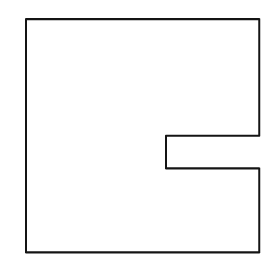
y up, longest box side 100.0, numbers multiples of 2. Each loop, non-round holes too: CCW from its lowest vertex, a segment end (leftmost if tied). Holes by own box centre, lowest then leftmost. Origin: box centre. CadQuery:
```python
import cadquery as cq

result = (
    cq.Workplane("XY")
    .moveTo(-50.0, -50.0)
    .lineTo(50.0, -50.0)
    .lineTo(50.0, -14.0)
    .lineTo(10.0, -14.0)
    .lineTo(10.0, 0.0)
    .lineTo(50.0, 0.0)
    .lineTo(50.0, 50.0)
    .lineTo(-50.0, 50.0)
    .close()
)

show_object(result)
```